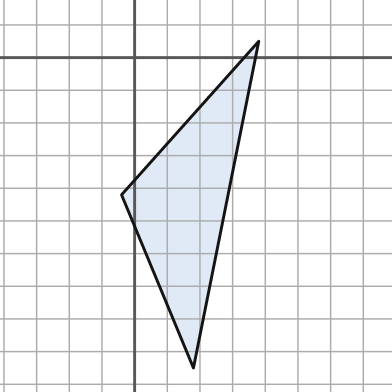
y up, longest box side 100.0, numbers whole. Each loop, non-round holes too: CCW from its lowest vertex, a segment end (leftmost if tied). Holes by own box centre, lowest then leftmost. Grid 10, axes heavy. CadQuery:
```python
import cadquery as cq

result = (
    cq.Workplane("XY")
    .moveTo(18.0, -95.0)
    .lineTo(38.0, 5.0)
    .lineTo(-4.0, -42.0)
    .close()
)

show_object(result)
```